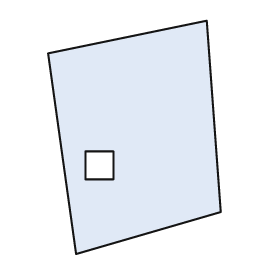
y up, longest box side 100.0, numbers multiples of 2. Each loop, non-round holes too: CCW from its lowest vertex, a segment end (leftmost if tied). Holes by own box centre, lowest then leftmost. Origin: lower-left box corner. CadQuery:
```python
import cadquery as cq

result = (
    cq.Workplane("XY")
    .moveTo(12.0, 0.0)
    .lineTo(74.0, 18.0)
    .lineTo(68.0, 100.0)
    .lineTo(0.0, 86.0)
    .close()
    .moveTo(16.0, 32.0)
    .lineTo(28.0, 32.0)
    .lineTo(28.0, 44.0)
    .lineTo(16.0, 44.0)
    .close()
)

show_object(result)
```